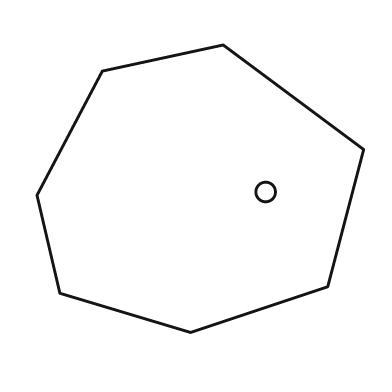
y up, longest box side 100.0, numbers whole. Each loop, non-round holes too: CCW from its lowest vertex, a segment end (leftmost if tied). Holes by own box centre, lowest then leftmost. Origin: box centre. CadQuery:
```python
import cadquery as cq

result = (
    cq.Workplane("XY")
    .moveTo(-3.0, -44.0)
    .lineTo(39.0, -30.0)
    .lineTo(50.0, 12.0)
    .lineTo(7.0, 44.0)
    .lineTo(-30.0, 36.0)
    .lineTo(-50.0, -2.0)
    .lineTo(-43.0, -32.0)
    .close()
    .moveTo(20.0, -1.0)
    .circle(3.0)
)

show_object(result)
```